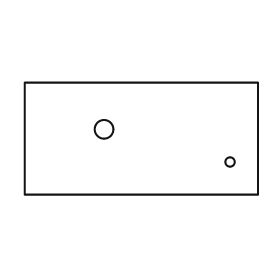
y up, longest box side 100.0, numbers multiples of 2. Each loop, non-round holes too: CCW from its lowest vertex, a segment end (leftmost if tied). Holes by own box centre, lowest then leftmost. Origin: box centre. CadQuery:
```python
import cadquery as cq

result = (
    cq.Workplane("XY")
    .moveTo(-50.0, -24.0)
    .lineTo(50.0, -24.0)
    .lineTo(50.0, 24.0)
    .lineTo(-50.0, 24.0)
    .close()
    .moveTo(38.0, -10.0)
    .circle(2.0)
    .moveTo(-16.0, 4.0)
    .circle(4.0)
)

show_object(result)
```